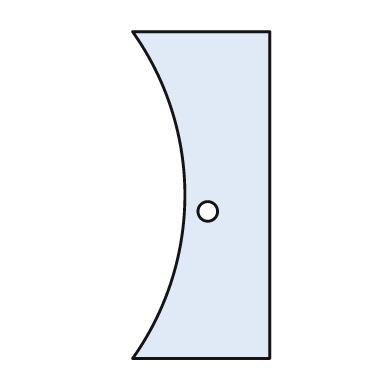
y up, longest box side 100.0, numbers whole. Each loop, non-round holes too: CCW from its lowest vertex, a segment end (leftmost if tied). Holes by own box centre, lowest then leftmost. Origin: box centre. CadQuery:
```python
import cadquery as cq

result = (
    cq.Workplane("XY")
    .moveTo(-21.0, -50.0)
    .lineTo(21.0, -50.0)
    .lineTo(21.0, 50.0)
    .lineTo(-21.0, 50.0)
    .threePointArc((-5.0, 0.0), (-21.0, -50.0))
    .close()
    .moveTo(2.0, -5.0)
    .circle(3.0)
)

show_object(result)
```